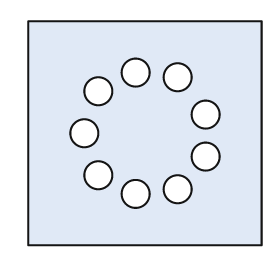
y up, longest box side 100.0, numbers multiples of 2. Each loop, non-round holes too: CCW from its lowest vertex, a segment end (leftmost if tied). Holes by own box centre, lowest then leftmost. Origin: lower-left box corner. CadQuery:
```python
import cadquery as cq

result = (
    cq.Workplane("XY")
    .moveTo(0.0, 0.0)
    .lineTo(100.0, 0.0)
    .lineTo(100.0, 96.0)
    .lineTo(0.0, 96.0)
    .close()
    .moveTo(46.0, 22.0)
    .circle(6.0)
    .moveTo(64.0, 24.0)
    .circle(6.0)
    .moveTo(30.0, 30.0)
    .circle(6.0)
    .moveTo(76.0, 38.0)
    .circle(6.0)
    .moveTo(24.0, 48.0)
    .circle(6.0)
    .moveTo(76.0, 56.0)
    .circle(6.0)
    .moveTo(30.0, 66.0)
    .circle(6.0)
    .moveTo(64.0, 72.0)
    .circle(6.0)
    .moveTo(46.0, 74.0)
    .circle(6.0)
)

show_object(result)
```